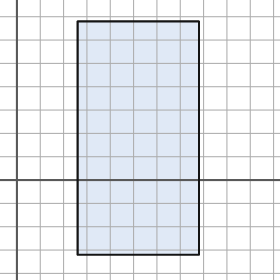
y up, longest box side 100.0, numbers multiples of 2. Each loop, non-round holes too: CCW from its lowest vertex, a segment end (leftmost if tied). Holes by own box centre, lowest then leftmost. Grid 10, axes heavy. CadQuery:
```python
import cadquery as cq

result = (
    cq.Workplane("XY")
    .moveTo(26.0, -32.0)
    .lineTo(78.0, -32.0)
    .lineTo(78.0, 68.0)
    .lineTo(26.0, 68.0)
    .close()
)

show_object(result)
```